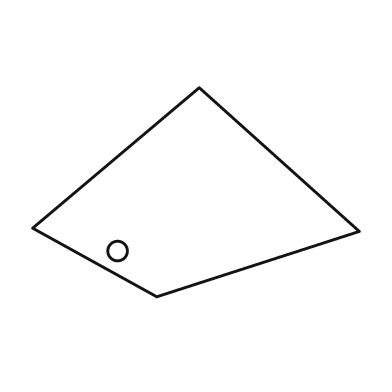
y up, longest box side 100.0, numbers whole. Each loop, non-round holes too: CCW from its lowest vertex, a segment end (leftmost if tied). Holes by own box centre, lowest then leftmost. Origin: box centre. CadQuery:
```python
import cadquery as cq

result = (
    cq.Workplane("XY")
    .moveTo(-12.0, -32.0)
    .lineTo(50.0, -12.0)
    .lineTo(1.0, 32.0)
    .lineTo(-50.0, -11.0)
    .close()
    .moveTo(-24.0, -18.0)
    .circle(3.0)
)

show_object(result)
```